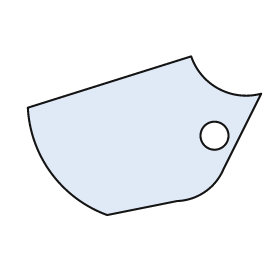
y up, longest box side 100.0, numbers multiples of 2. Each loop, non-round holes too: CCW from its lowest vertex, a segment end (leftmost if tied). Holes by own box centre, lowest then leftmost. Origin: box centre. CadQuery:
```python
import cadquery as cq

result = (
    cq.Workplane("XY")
    .moveTo(-16.0, -34.0)
    .lineTo(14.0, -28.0)
    .threePointArc((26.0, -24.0), (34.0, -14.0))
    .lineTo(50.0, 18.0)
    .threePointArc((32.0, 20.0), (20.0, 34.0))
    .lineTo(-50.0, 12.0)
    .threePointArc((-40.0, -16.0), (-16.0, -34.0))
    .close()
    .moveTo(30.0, 0.0)
    .circle(6.0)
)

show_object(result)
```